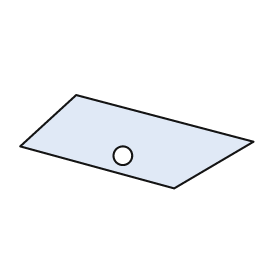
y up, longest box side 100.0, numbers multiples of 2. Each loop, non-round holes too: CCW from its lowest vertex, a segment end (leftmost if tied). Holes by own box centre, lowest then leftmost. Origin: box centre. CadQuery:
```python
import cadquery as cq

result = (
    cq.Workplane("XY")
    .moveTo(16.0, -20.0)
    .lineTo(50.0, 0.0)
    .lineTo(-26.0, 20.0)
    .lineTo(-50.0, -2.0)
    .close()
    .moveTo(-6.0, -6.0)
    .circle(4.0)
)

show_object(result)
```